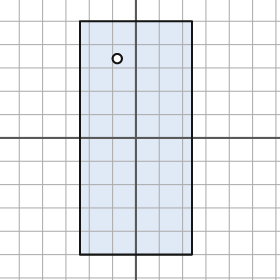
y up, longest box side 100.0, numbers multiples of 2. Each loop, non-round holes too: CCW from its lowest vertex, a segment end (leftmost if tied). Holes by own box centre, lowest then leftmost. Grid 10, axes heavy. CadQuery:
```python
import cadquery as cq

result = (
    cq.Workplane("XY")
    .moveTo(-24.0, -50.0)
    .lineTo(24.0, -50.0)
    .lineTo(24.0, 50.0)
    .lineTo(-24.0, 50.0)
    .close()
    .moveTo(-8.0, 34.0)
    .circle(2.0)
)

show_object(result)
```